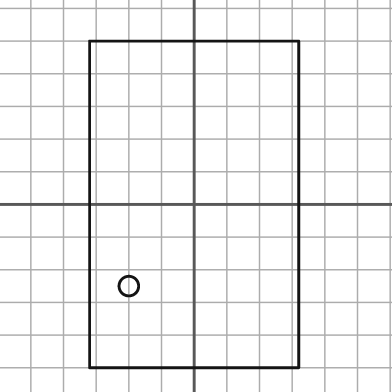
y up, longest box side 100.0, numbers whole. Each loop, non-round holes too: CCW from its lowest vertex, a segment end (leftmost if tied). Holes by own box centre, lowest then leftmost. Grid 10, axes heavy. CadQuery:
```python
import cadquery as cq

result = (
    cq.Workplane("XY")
    .moveTo(-32.0, -50.0)
    .lineTo(32.0, -50.0)
    .lineTo(32.0, 50.0)
    .lineTo(-32.0, 50.0)
    .close()
    .moveTo(-20.0, -25.0)
    .circle(3.0)
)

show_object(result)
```